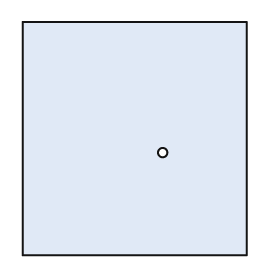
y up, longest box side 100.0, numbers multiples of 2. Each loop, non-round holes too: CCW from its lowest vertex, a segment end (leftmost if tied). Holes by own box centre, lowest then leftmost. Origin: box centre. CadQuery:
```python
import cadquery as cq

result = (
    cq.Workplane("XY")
    .moveTo(-48.0, -50.0)
    .lineTo(48.0, -50.0)
    .lineTo(48.0, 50.0)
    .lineTo(-48.0, 50.0)
    .close()
    .moveTo(12.0, -6.0)
    .circle(2.0)
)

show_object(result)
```